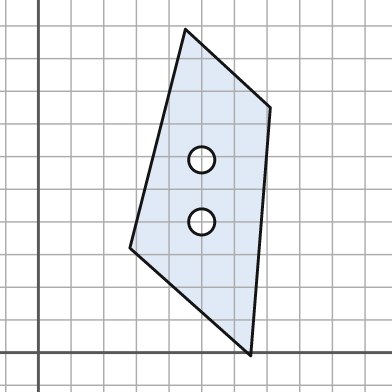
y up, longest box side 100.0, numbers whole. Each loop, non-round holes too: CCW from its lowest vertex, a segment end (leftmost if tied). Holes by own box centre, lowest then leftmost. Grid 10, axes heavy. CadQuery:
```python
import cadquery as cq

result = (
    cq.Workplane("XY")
    .moveTo(65.0, -1.0)
    .lineTo(71.0, 75.0)
    .lineTo(45.0, 99.0)
    .lineTo(28.0, 32.0)
    .close()
    .moveTo(50.0, 40.0)
    .circle(4.0)
    .moveTo(50.0, 59.0)
    .circle(4.0)
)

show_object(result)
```